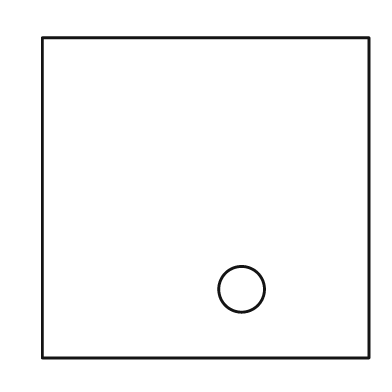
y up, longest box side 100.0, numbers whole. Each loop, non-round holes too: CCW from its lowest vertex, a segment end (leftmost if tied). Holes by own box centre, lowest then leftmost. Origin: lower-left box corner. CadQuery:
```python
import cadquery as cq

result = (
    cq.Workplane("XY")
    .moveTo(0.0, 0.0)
    .lineTo(100.0, 0.0)
    .lineTo(100.0, 98.0)
    .lineTo(0.0, 98.0)
    .close()
    .moveTo(61.0, 21.0)
    .circle(7.0)
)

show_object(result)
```